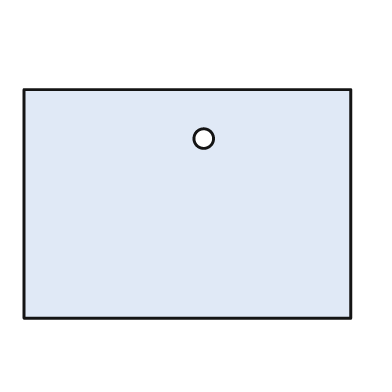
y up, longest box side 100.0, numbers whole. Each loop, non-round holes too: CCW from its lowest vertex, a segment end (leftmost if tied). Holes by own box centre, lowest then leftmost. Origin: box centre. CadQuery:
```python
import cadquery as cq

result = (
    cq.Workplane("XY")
    .moveTo(-50.0, -35.0)
    .lineTo(50.0, -35.0)
    .lineTo(50.0, 35.0)
    .lineTo(-50.0, 35.0)
    .close()
    .moveTo(5.0, 20.0)
    .circle(3.0)
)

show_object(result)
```